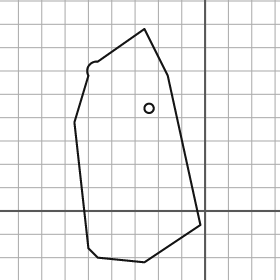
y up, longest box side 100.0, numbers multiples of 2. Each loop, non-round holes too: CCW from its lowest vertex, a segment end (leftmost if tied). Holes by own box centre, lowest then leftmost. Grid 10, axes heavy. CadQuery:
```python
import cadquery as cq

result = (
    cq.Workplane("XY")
    .moveTo(-26.0, -22.0)
    .lineTo(-2.0, -6.0)
    .lineTo(-16.0, 58.0)
    .lineTo(-26.0, 78.0)
    .lineTo(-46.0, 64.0)
    .threePointArc((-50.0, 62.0), (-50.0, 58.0))
    .lineTo(-56.0, 38.0)
    .lineTo(-50.0, -16.0)
    .lineTo(-46.0, -20.0)
    .close()
    .moveTo(-24.0, 44.0)
    .circle(2.0)
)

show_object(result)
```